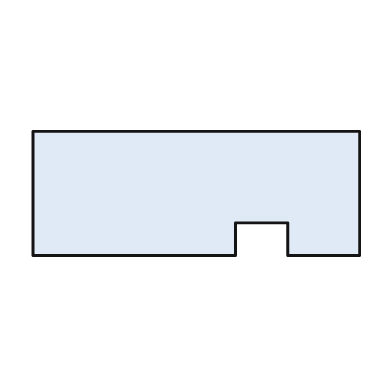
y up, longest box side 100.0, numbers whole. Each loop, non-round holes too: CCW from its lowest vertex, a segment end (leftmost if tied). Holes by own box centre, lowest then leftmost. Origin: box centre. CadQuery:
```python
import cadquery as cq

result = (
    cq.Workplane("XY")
    .moveTo(-50.0, -19.0)
    .lineTo(12.0, -19.0)
    .lineTo(12.0, -9.0)
    .lineTo(28.0, -9.0)
    .lineTo(28.0, -19.0)
    .lineTo(50.0, -19.0)
    .lineTo(50.0, 19.0)
    .lineTo(-50.0, 19.0)
    .close()
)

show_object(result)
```